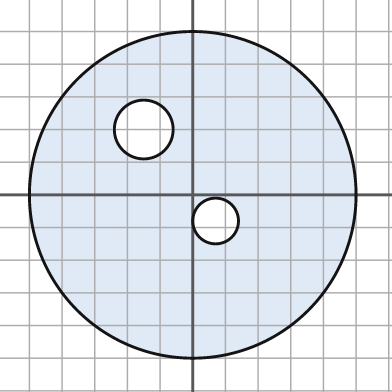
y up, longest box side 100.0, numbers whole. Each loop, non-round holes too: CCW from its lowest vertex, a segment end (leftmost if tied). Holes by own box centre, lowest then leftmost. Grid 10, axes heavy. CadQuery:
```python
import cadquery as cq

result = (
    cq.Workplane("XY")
    .moveTo(0.0, 0.0)
    .circle(50.0)
    .moveTo(7.0, -8.0)
    .circle(7.0)
    .moveTo(-15.0, 20.0)
    .circle(9.0)
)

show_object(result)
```